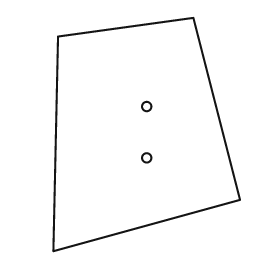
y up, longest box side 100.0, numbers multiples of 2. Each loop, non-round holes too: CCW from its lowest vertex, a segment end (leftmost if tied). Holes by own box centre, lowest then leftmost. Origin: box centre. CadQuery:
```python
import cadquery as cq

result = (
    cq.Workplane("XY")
    .moveTo(-40.0, -50.0)
    .lineTo(40.0, -28.0)
    .lineTo(20.0, 50.0)
    .lineTo(-38.0, 42.0)
    .close()
    .moveTo(0.0, -10.0)
    .circle(2.0)
    .moveTo(0.0, 12.0)
    .circle(2.0)
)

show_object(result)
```